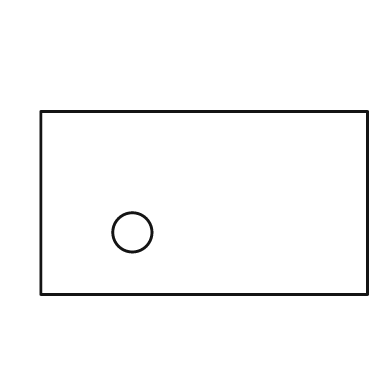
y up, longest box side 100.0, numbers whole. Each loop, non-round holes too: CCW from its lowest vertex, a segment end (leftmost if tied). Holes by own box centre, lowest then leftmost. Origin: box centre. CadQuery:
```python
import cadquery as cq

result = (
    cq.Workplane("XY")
    .moveTo(-50.0, -28.0)
    .lineTo(50.0, -28.0)
    .lineTo(50.0, 28.0)
    .lineTo(-50.0, 28.0)
    .close()
    .moveTo(-22.0, -9.0)
    .circle(6.0)
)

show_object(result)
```